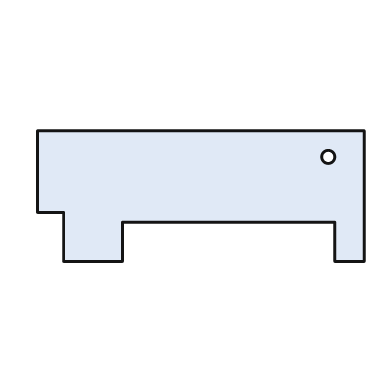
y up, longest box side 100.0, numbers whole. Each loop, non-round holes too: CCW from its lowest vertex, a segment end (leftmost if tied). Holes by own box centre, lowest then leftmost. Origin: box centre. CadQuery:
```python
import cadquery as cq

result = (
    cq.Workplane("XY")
    .moveTo(-42.0, -20.0)
    .lineTo(-24.0, -20.0)
    .lineTo(-24.0, -8.0)
    .lineTo(41.0, -8.0)
    .lineTo(41.0, -20.0)
    .lineTo(50.0, -20.0)
    .lineTo(50.0, 20.0)
    .lineTo(-50.0, 20.0)
    .lineTo(-50.0, -5.0)
    .lineTo(-42.0, -5.0)
    .close()
    .moveTo(39.0, 12.0)
    .circle(2.0)
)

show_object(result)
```